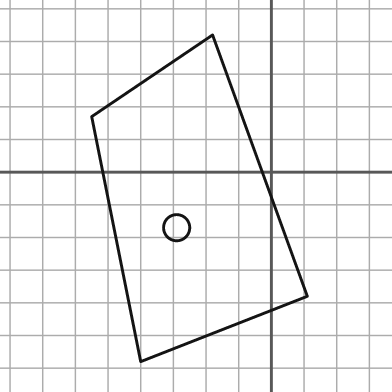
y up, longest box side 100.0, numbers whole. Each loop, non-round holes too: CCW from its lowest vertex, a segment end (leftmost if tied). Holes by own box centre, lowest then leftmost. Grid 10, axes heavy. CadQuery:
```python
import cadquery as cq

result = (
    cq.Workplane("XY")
    .moveTo(-40.0, -58.0)
    .lineTo(11.0, -38.0)
    .lineTo(-18.0, 42.0)
    .lineTo(-55.0, 17.0)
    .close()
    .moveTo(-29.0, -17.0)
    .circle(4.0)
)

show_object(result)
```